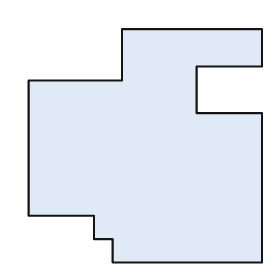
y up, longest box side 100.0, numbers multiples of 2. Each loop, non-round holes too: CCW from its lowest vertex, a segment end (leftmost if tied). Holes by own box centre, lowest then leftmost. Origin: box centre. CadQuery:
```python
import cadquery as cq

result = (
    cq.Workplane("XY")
    .moveTo(-14.0, -50.0)
    .lineTo(50.0, -50.0)
    .lineTo(50.0, 14.0)
    .lineTo(22.0, 14.0)
    .lineTo(22.0, 34.0)
    .lineTo(50.0, 34.0)
    .lineTo(50.0, 50.0)
    .lineTo(-10.0, 50.0)
    .lineTo(-10.0, 28.0)
    .lineTo(-50.0, 28.0)
    .lineTo(-50.0, -30.0)
    .lineTo(-22.0, -30.0)
    .lineTo(-22.0, -40.0)
    .lineTo(-14.0, -40.0)
    .close()
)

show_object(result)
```